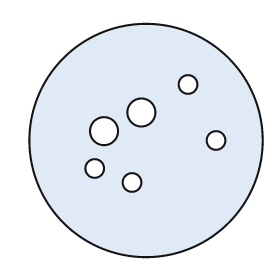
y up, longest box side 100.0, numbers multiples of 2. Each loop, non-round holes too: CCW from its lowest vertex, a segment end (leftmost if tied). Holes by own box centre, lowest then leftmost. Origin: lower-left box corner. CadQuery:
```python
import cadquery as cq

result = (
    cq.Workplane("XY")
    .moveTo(50.0, 50.0)
    .circle(50.0)
    .moveTo(44.0, 32.0)
    .circle(4.0)
    .moveTo(28.0, 38.0)
    .circle(4.0)
    .moveTo(80.0, 50.0)
    .circle(4.0)
    .moveTo(32.0, 54.0)
    .circle(6.0)
    .moveTo(48.0, 62.0)
    .circle(6.0)
    .moveTo(68.0, 74.0)
    .circle(4.0)
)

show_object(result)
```